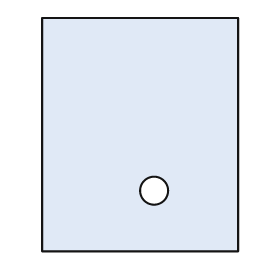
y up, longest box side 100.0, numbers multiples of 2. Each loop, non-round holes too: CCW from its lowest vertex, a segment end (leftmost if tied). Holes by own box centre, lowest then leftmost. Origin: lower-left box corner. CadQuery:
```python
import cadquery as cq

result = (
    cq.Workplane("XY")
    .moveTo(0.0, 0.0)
    .lineTo(84.0, 0.0)
    .lineTo(84.0, 100.0)
    .lineTo(0.0, 100.0)
    .close()
    .moveTo(48.0, 26.0)
    .circle(6.0)
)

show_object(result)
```